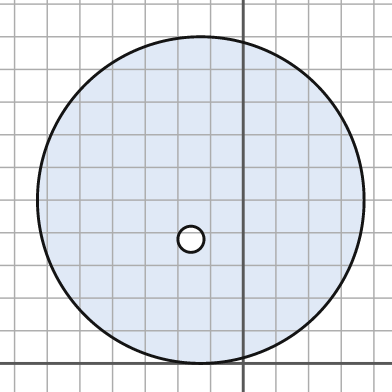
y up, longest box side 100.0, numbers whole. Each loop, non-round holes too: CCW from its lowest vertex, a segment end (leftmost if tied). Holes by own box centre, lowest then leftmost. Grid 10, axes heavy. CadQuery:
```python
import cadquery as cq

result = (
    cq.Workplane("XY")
    .moveTo(-13.0, 50.0)
    .circle(50.0)
    .moveTo(-16.0, 38.0)
    .circle(4.0)
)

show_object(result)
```